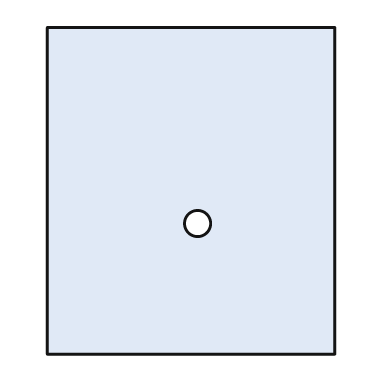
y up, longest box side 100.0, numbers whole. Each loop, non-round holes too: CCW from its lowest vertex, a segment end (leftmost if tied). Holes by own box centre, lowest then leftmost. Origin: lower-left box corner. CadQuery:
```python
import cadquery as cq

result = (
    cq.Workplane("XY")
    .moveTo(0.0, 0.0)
    .lineTo(88.0, 0.0)
    .lineTo(88.0, 100.0)
    .lineTo(0.0, 100.0)
    .close()
    .moveTo(46.0, 40.0)
    .circle(4.0)
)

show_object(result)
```